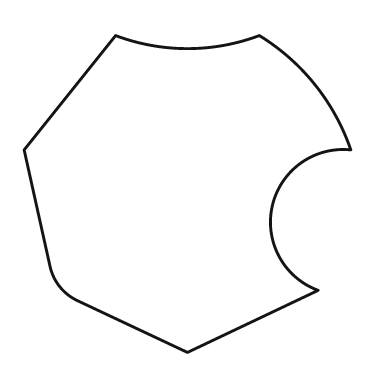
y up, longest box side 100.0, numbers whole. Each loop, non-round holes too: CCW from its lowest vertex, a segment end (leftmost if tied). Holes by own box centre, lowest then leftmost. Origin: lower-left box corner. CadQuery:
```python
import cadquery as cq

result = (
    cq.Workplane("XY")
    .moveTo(50.0, 0.0)
    .lineTo(90.0, 19.0)
    .threePointArc((76.0, 45.0), (100.0, 62.0))
    .threePointArc((89.0, 82.0), (72.0, 97.0))
    .threePointArc((50.0, 93.0), (28.0, 97.0))
    .lineTo(0.0, 62.0)
    .lineTo(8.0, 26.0)
    .threePointArc((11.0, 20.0), (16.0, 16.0))
    .close()
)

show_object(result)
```